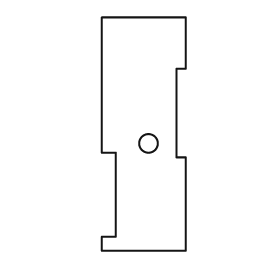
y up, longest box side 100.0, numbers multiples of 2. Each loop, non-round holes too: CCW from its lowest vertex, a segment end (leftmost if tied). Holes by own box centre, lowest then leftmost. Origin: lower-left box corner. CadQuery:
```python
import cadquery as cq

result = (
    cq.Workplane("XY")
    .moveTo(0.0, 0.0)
    .lineTo(36.0, 0.0)
    .lineTo(36.0, 40.0)
    .lineTo(32.0, 40.0)
    .lineTo(32.0, 78.0)
    .lineTo(36.0, 78.0)
    .lineTo(36.0, 100.0)
    .lineTo(0.0, 100.0)
    .lineTo(0.0, 42.0)
    .lineTo(6.0, 42.0)
    .lineTo(6.0, 6.0)
    .lineTo(0.0, 6.0)
    .close()
    .moveTo(20.0, 46.0)
    .circle(4.0)
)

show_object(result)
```